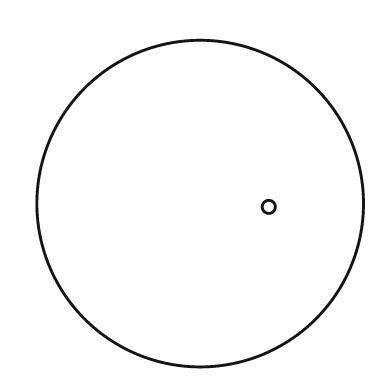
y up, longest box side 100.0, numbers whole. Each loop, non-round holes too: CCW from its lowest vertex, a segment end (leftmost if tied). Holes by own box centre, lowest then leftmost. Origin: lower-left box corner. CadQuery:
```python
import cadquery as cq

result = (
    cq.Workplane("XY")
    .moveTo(50.0, 50.0)
    .circle(50.0)
    .moveTo(71.0, 49.0)
    .circle(2.0)
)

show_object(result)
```